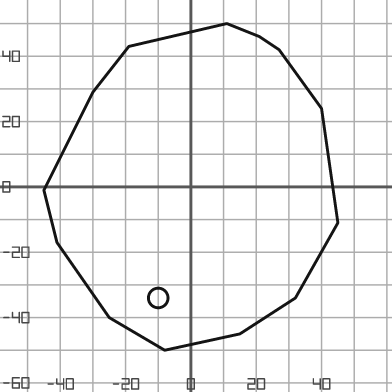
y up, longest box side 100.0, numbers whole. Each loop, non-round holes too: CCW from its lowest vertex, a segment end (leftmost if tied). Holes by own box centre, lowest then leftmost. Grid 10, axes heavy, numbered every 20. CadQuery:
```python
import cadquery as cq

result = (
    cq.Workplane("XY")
    .moveTo(-8.0, -50.0)
    .lineTo(15.0, -45.0)
    .lineTo(32.0, -34.0)
    .lineTo(45.0, -11.0)
    .lineTo(40.0, 24.0)
    .lineTo(27.0, 42.0)
    .lineTo(21.0, 46.0)
    .lineTo(11.0, 50.0)
    .lineTo(-19.0, 43.0)
    .lineTo(-30.0, 29.0)
    .lineTo(-45.0, -1.0)
    .lineTo(-41.0, -17.0)
    .lineTo(-25.0, -40.0)
    .close()
    .moveTo(-10.0, -34.0)
    .circle(3.0)
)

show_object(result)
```